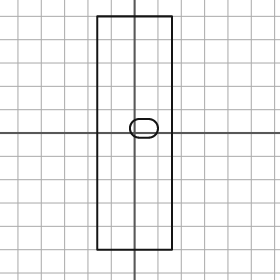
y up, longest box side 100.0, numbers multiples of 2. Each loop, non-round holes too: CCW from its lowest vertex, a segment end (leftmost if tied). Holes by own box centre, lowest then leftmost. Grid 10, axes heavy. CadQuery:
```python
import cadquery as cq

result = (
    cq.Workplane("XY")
    .moveTo(-16.0, -50.0)
    .lineTo(16.0, -50.0)
    .lineTo(16.0, 50.0)
    .lineTo(-16.0, 50.0)
    .close()
    .moveTo(2.0, -2.0)
    .lineTo(6.0, -2.0)
    .threePointArc((10.0, 2.0), (6.0, 6.0))
    .lineTo(2.0, 6.0)
    .threePointArc((-2.0, 2.0), (2.0, -2.0))
    .close()
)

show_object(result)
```